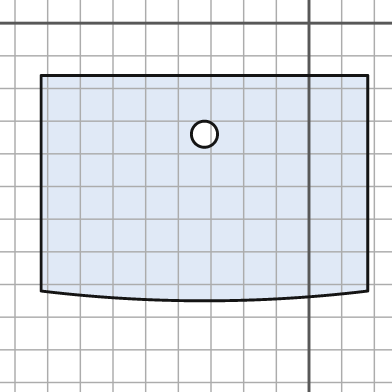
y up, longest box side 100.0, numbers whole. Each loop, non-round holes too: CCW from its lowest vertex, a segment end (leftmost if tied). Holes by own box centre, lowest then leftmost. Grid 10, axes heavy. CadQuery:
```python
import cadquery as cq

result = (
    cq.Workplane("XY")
    .moveTo(-82.0, -82.0)
    .threePointArc((-32.0, -85.0), (18.0, -82.0))
    .lineTo(18.0, -16.0)
    .lineTo(-82.0, -16.0)
    .close()
    .moveTo(-32.0, -34.0)
    .circle(4.0)
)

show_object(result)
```